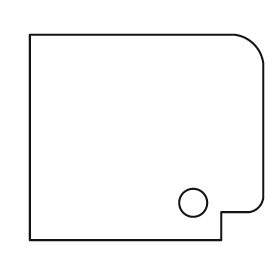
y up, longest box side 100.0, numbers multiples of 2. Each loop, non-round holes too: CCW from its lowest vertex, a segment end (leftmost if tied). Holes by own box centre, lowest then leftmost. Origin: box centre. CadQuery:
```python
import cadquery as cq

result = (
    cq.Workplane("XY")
    .moveTo(-50.0, -44.0)
    .lineTo(32.0, -44.0)
    .lineTo(32.0, -32.0)
    .lineTo(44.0, -32.0)
    .threePointArc((48.0, -30.0), (50.0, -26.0))
    .lineTo(50.0, 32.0)
    .threePointArc((46.0, 40.0), (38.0, 44.0))
    .lineTo(-50.0, 44.0)
    .close()
    .moveTo(20.0, -28.0)
    .circle(6.0)
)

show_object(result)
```